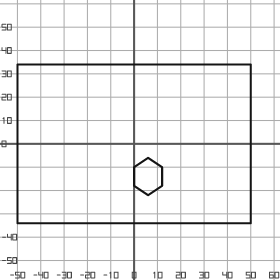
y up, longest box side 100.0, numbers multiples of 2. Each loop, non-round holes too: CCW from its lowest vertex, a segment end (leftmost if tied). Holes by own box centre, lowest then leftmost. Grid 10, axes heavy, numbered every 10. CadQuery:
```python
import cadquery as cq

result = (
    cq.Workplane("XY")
    .moveTo(-50.0, -34.0)
    .lineTo(50.0, -34.0)
    .lineTo(50.0, 34.0)
    .lineTo(-50.0, 34.0)
    .close()
    .moveTo(6.0, -22.0)
    .lineTo(12.0, -18.0)
    .lineTo(12.0, -10.0)
    .lineTo(6.0, -6.0)
    .lineTo(0.0, -10.0)
    .lineTo(0.0, -18.0)
    .close()
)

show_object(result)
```